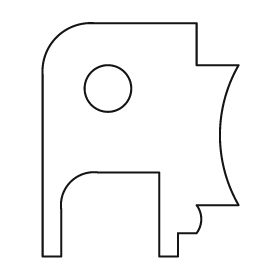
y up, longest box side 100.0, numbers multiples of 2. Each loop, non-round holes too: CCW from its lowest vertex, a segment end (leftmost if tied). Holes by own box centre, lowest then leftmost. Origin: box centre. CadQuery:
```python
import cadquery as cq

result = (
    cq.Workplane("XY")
    .moveTo(-42.0, -50.0)
    .lineTo(-34.0, -50.0)
    .lineTo(-34.0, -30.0)
    .threePointArc((-30.0, -18.0), (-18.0, -14.0))
    .lineTo(8.0, -14.0)
    .lineTo(8.0, -50.0)
    .lineTo(16.0, -50.0)
    .lineTo(16.0, -40.0)
    .lineTo(24.0, -40.0)
    .threePointArc((26.0, -34.0), (24.0, -28.0))
    .lineTo(42.0, -28.0)
    .threePointArc((34.0, 2.0), (42.0, 32.0))
    .lineTo(24.0, 32.0)
    .lineTo(24.0, 50.0)
    .lineTo(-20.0, 50.0)
    .threePointArc((-36.0, 44.0), (-42.0, 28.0))
    .close()
    .moveTo(-14.0, 22.0)
    .circle(10.0)
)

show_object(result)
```